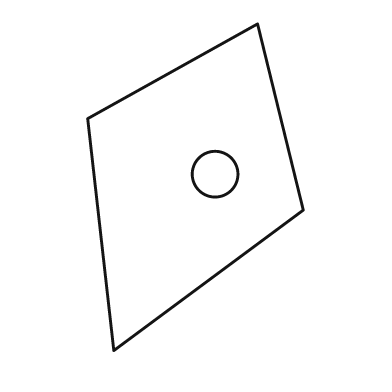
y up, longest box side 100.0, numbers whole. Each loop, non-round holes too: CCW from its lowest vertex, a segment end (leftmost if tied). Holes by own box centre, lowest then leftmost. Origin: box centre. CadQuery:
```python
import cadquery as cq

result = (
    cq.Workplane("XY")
    .moveTo(-25.0, -50.0)
    .lineTo(33.0, -7.0)
    .lineTo(19.0, 50.0)
    .lineTo(-33.0, 21.0)
    .close()
    .moveTo(6.0, 4.0)
    .circle(7.0)
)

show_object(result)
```